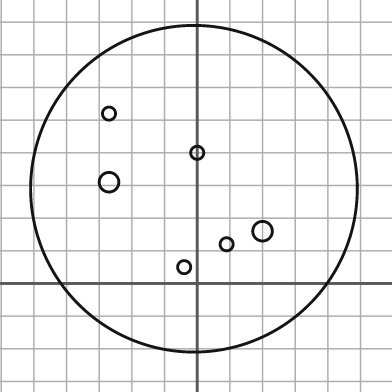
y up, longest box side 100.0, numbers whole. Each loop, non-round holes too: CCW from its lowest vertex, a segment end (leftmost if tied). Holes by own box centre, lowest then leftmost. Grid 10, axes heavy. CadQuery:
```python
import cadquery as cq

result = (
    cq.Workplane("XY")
    .moveTo(-1.0, 29.0)
    .circle(50.0)
    .moveTo(-4.0, 5.0)
    .circle(2.0)
    .moveTo(9.0, 12.0)
    .circle(2.0)
    .moveTo(20.0, 16.0)
    .circle(3.0)
    .moveTo(-27.0, 31.0)
    .circle(3.0)
    .moveTo(0.0, 40.0)
    .circle(2.0)
    .moveTo(-27.0, 52.0)
    .circle(2.0)
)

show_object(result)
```